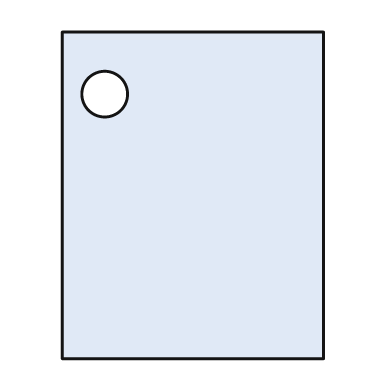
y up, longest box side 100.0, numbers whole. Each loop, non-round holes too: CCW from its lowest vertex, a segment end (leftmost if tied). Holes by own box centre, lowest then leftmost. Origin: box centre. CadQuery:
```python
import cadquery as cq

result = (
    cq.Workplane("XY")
    .moveTo(-40.0, -50.0)
    .lineTo(40.0, -50.0)
    .lineTo(40.0, 50.0)
    .lineTo(-40.0, 50.0)
    .close()
    .moveTo(-27.0, 31.0)
    .circle(7.0)
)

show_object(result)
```